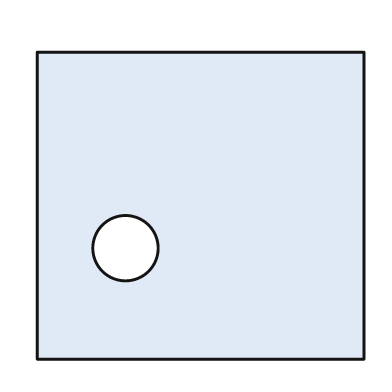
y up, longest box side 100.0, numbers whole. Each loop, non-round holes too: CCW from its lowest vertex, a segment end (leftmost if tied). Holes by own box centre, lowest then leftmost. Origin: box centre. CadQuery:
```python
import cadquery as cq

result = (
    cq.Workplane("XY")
    .moveTo(-50.0, -47.0)
    .lineTo(50.0, -47.0)
    .lineTo(50.0, 47.0)
    .lineTo(-50.0, 47.0)
    .close()
    .moveTo(-23.0, -13.0)
    .circle(10.0)
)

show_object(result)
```